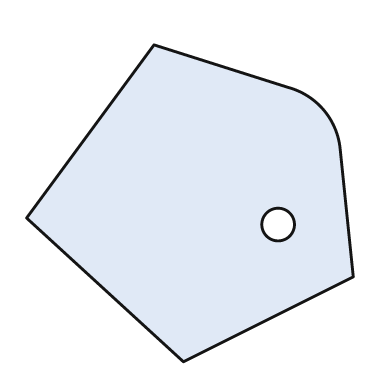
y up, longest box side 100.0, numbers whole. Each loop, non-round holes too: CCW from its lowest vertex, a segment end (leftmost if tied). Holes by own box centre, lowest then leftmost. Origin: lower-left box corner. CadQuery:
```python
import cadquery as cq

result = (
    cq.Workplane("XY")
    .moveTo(48.0, 0.0)
    .lineTo(100.0, 26.0)
    .lineTo(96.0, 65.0)
    .threePointArc((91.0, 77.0), (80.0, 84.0))
    .lineTo(39.0, 97.0)
    .lineTo(0.0, 44.0)
    .close()
    .moveTo(77.0, 42.0)
    .circle(5.0)
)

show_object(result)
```